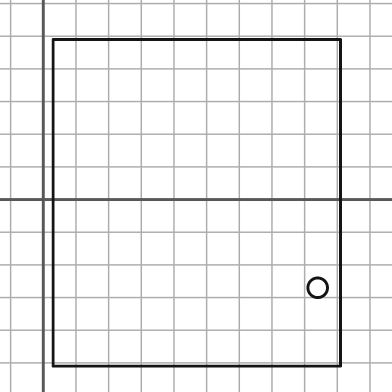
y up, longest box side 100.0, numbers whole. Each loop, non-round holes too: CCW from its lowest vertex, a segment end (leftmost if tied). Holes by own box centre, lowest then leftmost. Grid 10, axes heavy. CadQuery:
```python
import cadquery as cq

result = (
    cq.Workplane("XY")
    .moveTo(3.0, -51.0)
    .lineTo(91.0, -51.0)
    .lineTo(91.0, 49.0)
    .lineTo(3.0, 49.0)
    .close()
    .moveTo(84.0, -27.0)
    .circle(3.0)
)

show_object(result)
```